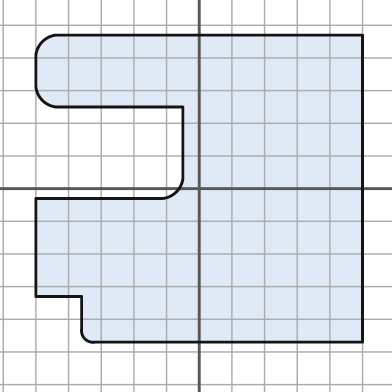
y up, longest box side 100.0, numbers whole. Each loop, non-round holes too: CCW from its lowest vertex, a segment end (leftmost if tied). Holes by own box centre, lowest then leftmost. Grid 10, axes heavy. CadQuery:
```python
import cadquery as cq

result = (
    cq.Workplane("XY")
    .moveTo(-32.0, -47.0)
    .lineTo(50.0, -47.0)
    .lineTo(50.0, 47.0)
    .lineTo(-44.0, 47.0)
    .threePointArc((-48.0, 45.0), (-50.0, 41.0))
    .lineTo(-50.0, 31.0)
    .threePointArc((-48.0, 27.0), (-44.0, 25.0))
    .lineTo(-5.0, 25.0)
    .lineTo(-5.0, 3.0)
    .threePointArc((-7.0, -1.0), (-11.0, -3.0))
    .lineTo(-50.0, -3.0)
    .lineTo(-50.0, -33.0)
    .lineTo(-36.0, -33.0)
    .lineTo(-36.0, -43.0)
    .threePointArc((-35.0, -46.0), (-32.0, -47.0))
    .close()
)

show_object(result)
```